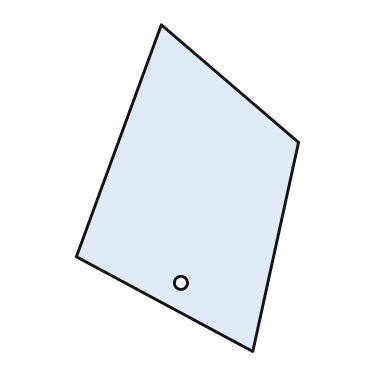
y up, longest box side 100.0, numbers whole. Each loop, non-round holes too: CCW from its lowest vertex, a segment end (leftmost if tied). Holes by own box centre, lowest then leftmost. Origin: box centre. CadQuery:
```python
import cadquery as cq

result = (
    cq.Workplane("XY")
    .moveTo(20.0, -50.0)
    .lineTo(34.0, 14.0)
    .lineTo(-8.0, 50.0)
    .lineTo(-34.0, -21.0)
    .close()
    .moveTo(-2.0, -29.0)
    .circle(2.0)
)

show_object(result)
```